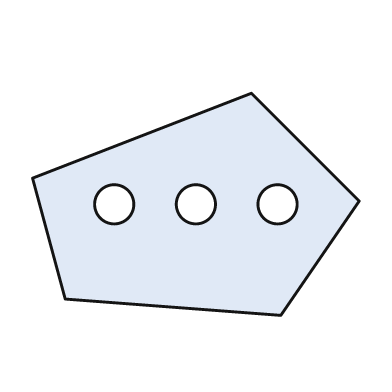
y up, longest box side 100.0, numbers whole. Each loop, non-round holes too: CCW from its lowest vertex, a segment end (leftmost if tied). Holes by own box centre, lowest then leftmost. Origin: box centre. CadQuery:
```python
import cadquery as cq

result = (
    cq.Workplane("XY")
    .moveTo(26.0, -34.0)
    .lineTo(50.0, 1.0)
    .lineTo(17.0, 34.0)
    .lineTo(-50.0, 8.0)
    .lineTo(-40.0, -29.0)
    .close()
    .moveTo(-25.0, 0.0)
    .circle(6.0)
    .moveTo(0.0, 0.0)
    .circle(6.0)
    .moveTo(25.0, 0.0)
    .circle(6.0)
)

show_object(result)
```